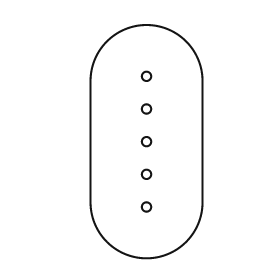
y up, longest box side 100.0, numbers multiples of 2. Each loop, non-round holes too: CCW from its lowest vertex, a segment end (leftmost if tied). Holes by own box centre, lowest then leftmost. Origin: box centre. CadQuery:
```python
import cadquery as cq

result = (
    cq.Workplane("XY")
    .moveTo(-24.0, -26.0)
    .threePointArc((0.0, -50.0), (24.0, -26.0))
    .lineTo(24.0, 26.0)
    .threePointArc((0.0, 50.0), (-24.0, 26.0))
    .close()
    .moveTo(0.0, -28.0)
    .circle(2.0)
    .moveTo(0.0, -14.0)
    .circle(2.0)
    .moveTo(0.0, 0.0)
    .circle(2.0)
    .moveTo(0.0, 14.0)
    .circle(2.0)
    .moveTo(0.0, 28.0)
    .circle(2.0)
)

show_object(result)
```